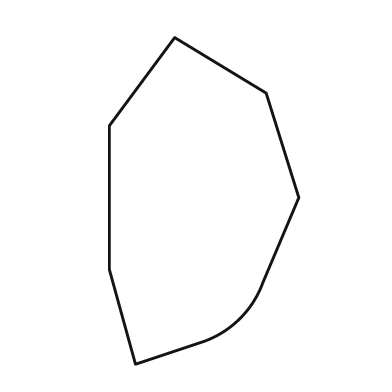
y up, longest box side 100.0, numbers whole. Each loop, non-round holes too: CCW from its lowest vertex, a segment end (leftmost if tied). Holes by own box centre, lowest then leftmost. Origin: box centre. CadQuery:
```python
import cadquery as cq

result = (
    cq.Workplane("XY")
    .moveTo(-21.0, -50.0)
    .lineTo(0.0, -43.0)
    .threePointArc((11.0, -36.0), (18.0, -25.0))
    .lineTo(29.0, 1.0)
    .lineTo(19.0, 33.0)
    .lineTo(-9.0, 50.0)
    .lineTo(-29.0, 23.0)
    .lineTo(-29.0, -21.0)
    .close()
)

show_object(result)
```